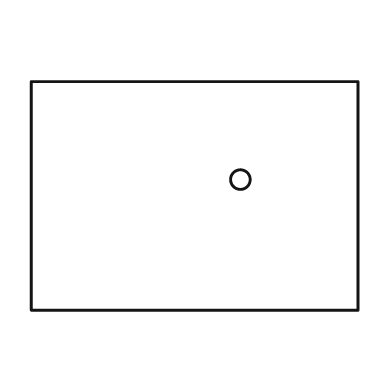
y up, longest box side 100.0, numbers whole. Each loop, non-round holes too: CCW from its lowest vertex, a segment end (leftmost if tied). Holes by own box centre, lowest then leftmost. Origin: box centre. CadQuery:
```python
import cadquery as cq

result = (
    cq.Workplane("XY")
    .moveTo(-50.0, -35.0)
    .lineTo(50.0, -35.0)
    .lineTo(50.0, 35.0)
    .lineTo(-50.0, 35.0)
    .close()
    .moveTo(14.0, 5.0)
    .circle(3.0)
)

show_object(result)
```